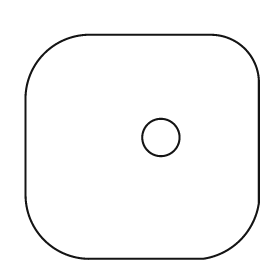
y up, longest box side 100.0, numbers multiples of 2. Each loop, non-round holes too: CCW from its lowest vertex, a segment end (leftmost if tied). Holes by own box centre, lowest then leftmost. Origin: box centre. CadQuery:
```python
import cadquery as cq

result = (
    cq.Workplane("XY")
    .moveTo(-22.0, -48.0)
    .lineTo(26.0, -48.0)
    .threePointArc((42.0, -40.0), (50.0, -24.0))
    .lineTo(50.0, 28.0)
    .threePointArc((44.0, 42.0), (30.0, 48.0))
    .lineTo(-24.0, 48.0)
    .threePointArc((-42.0, 40.0), (-50.0, 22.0))
    .lineTo(-50.0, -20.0)
    .threePointArc((-42.0, -40.0), (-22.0, -48.0))
    .close()
    .moveTo(8.0, 4.0)
    .circle(8.0)
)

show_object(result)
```